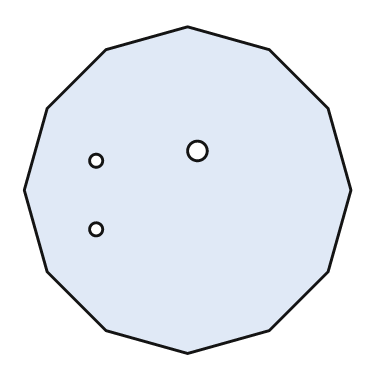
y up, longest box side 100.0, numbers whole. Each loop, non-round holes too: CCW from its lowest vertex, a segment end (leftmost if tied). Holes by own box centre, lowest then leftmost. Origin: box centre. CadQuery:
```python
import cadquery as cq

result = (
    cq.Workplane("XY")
    .moveTo(0.0, -50.0)
    .lineTo(25.0, -43.0)
    .lineTo(43.0, -25.0)
    .lineTo(50.0, 0.0)
    .lineTo(43.0, 25.0)
    .lineTo(25.0, 43.0)
    .lineTo(0.0, 50.0)
    .lineTo(-25.0, 43.0)
    .lineTo(-43.0, 25.0)
    .lineTo(-50.0, 0.0)
    .lineTo(-43.0, -25.0)
    .lineTo(-25.0, -43.0)
    .close()
    .moveTo(-28.0, -12.0)
    .circle(2.0)
    .moveTo(-28.0, 9.0)
    .circle(2.0)
    .moveTo(3.0, 12.0)
    .circle(3.0)
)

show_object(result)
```